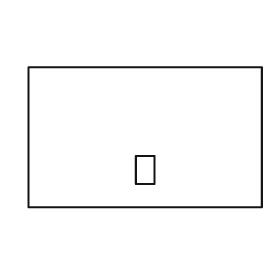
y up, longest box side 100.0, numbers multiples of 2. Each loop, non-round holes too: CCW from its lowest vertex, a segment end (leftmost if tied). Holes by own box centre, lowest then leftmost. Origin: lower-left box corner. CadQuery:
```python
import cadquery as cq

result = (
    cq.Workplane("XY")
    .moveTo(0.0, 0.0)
    .lineTo(100.0, 0.0)
    .lineTo(100.0, 60.0)
    .lineTo(0.0, 60.0)
    .close()
    .moveTo(46.0, 10.0)
    .lineTo(54.0, 10.0)
    .lineTo(54.0, 22.0)
    .lineTo(46.0, 22.0)
    .close()
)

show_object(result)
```